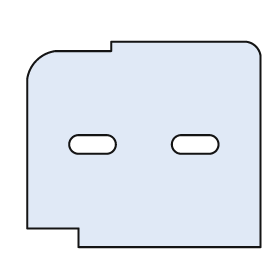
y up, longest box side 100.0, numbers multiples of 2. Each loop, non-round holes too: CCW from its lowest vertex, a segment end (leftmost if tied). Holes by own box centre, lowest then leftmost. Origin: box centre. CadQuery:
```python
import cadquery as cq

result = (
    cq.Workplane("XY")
    .moveTo(-28.0, -44.0)
    .lineTo(50.0, -44.0)
    .lineTo(50.0, 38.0)
    .threePointArc((48.0, 42.0), (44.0, 44.0))
    .lineTo(-14.0, 44.0)
    .lineTo(-14.0, 40.0)
    .lineTo(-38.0, 40.0)
    .threePointArc((-46.0, 36.0), (-50.0, 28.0))
    .lineTo(-50.0, -36.0)
    .lineTo(-28.0, -36.0)
    .close()
    .moveTo(-28.0, -4.0)
    .lineTo(-16.0, -4.0)
    .threePointArc((-12.0, 0.0), (-16.0, 4.0))
    .lineTo(-28.0, 4.0)
    .threePointArc((-32.0, 0.0), (-28.0, -4.0))
    .close()
    .moveTo(16.0, -4.0)
    .lineTo(28.0, -4.0)
    .threePointArc((32.0, 0.0), (28.0, 4.0))
    .lineTo(16.0, 4.0)
    .threePointArc((12.0, 0.0), (16.0, -4.0))
    .close()
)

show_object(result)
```